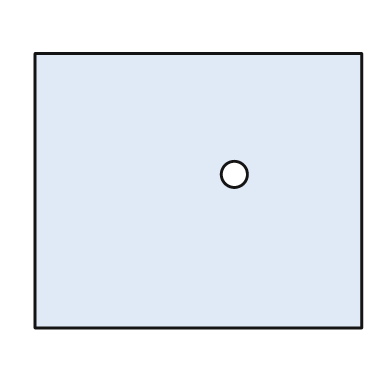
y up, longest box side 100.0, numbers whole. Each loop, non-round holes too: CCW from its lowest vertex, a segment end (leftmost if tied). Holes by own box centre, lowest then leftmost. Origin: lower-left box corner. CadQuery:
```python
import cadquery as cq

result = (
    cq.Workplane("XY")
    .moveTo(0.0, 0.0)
    .lineTo(100.0, 0.0)
    .lineTo(100.0, 84.0)
    .lineTo(0.0, 84.0)
    .close()
    .moveTo(61.0, 47.0)
    .circle(4.0)
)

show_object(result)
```